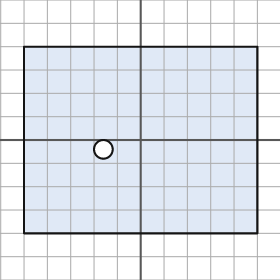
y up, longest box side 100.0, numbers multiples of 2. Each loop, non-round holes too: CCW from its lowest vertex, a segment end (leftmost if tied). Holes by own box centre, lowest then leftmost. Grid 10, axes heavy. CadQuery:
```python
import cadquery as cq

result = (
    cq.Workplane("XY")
    .moveTo(-50.0, -40.0)
    .lineTo(50.0, -40.0)
    .lineTo(50.0, 40.0)
    .lineTo(-50.0, 40.0)
    .close()
    .moveTo(-16.0, -4.0)
    .circle(4.0)
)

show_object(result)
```